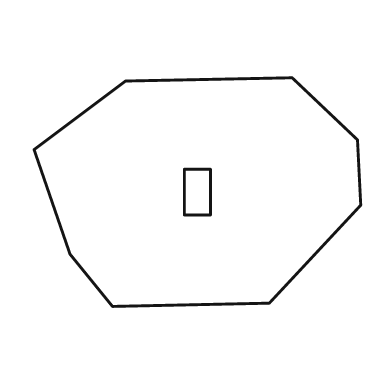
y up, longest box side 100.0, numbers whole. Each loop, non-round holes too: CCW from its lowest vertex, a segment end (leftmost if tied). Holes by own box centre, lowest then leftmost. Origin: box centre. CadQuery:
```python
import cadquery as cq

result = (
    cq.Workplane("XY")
    .moveTo(-26.0, -35.0)
    .lineTo(22.0, -34.0)
    .lineTo(50.0, -4.0)
    .lineTo(49.0, 16.0)
    .lineTo(29.0, 35.0)
    .lineTo(-22.0, 34.0)
    .lineTo(-50.0, 13.0)
    .lineTo(-39.0, -19.0)
    .close()
    .moveTo(-4.0, -7.0)
    .lineTo(4.0, -7.0)
    .lineTo(4.0, 7.0)
    .lineTo(-4.0, 7.0)
    .close()
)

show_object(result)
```